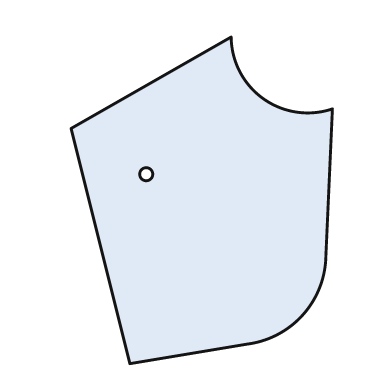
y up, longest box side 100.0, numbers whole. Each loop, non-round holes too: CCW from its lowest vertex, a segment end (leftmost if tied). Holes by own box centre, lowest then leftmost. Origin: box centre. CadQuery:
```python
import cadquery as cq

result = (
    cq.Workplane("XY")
    .moveTo(-22.0, -50.0)
    .lineTo(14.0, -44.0)
    .threePointArc((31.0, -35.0), (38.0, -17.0))
    .lineTo(40.0, 28.0)
    .threePointArc((19.0, 31.0), (9.0, 50.0))
    .lineTo(-40.0, 22.0)
    .close()
    .moveTo(-17.0, 8.0)
    .circle(2.0)
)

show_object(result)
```